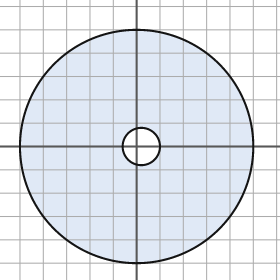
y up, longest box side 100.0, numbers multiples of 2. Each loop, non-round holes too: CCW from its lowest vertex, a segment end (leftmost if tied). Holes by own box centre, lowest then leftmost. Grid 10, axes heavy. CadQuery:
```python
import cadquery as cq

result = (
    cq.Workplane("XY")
    .moveTo(0.0, 0.0)
    .circle(50.0)
    .moveTo(2.0, 0.0)
    .circle(8.0)
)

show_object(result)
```